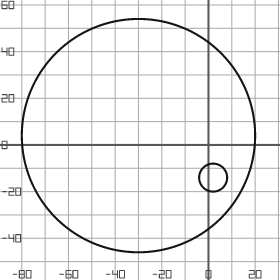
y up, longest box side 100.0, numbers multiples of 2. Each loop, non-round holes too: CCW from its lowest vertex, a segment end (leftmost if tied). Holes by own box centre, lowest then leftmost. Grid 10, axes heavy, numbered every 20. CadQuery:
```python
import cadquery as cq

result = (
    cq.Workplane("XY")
    .moveTo(-30.0, 4.0)
    .circle(50.0)
    .moveTo(2.0, -14.0)
    .circle(6.0)
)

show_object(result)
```